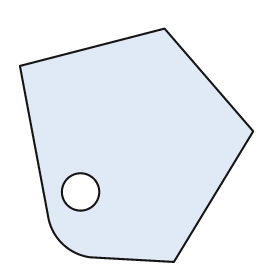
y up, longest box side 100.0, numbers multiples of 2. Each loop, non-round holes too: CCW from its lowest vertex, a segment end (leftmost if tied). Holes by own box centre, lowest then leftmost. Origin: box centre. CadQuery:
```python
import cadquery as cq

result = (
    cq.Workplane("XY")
    .moveTo(16.0, -50.0)
    .lineTo(50.0, 6.0)
    .lineTo(12.0, 50.0)
    .lineTo(-50.0, 34.0)
    .lineTo(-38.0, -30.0)
    .threePointArc((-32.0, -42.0), (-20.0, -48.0))
    .close()
    .moveTo(-24.0, -20.0)
    .circle(8.0)
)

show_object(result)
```